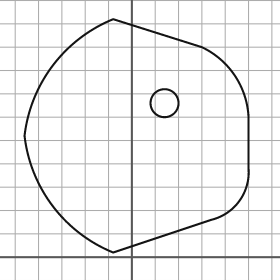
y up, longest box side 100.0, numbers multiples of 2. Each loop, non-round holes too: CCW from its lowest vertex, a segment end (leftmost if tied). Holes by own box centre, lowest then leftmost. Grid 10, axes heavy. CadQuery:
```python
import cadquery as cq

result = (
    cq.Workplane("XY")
    .moveTo(-8.0, 2.0)
    .lineTo(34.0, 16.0)
    .threePointArc((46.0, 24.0), (50.0, 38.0))
    .lineTo(50.0, 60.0)
    .threePointArc((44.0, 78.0), (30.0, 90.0))
    .lineTo(-8.0, 102.0)
    .threePointArc((-34.0, 82.0), (-46.0, 52.0))
    .threePointArc((-34.0, 22.0), (-8.0, 2.0))
    .close()
    .moveTo(14.0, 66.0)
    .circle(6.0)
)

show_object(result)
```